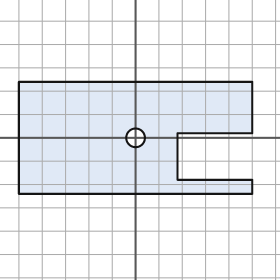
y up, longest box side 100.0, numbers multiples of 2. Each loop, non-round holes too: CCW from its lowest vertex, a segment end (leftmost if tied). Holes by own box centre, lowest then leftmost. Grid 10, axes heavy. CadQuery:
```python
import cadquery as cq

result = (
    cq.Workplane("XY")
    .moveTo(-50.0, -24.0)
    .lineTo(50.0, -24.0)
    .lineTo(50.0, -18.0)
    .lineTo(18.0, -18.0)
    .lineTo(18.0, 2.0)
    .lineTo(50.0, 2.0)
    .lineTo(50.0, 24.0)
    .lineTo(-50.0, 24.0)
    .close()
    .moveTo(0.0, 0.0)
    .circle(4.0)
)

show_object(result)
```